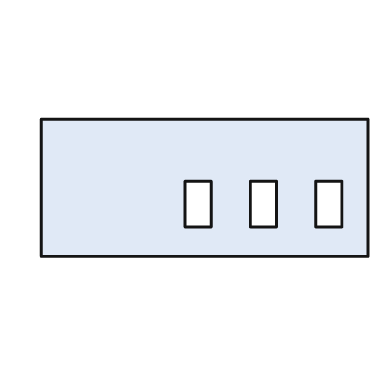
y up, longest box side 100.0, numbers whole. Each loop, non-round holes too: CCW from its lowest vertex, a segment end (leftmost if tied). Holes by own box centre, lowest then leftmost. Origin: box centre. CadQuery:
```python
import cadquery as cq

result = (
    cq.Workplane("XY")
    .moveTo(-50.0, -21.0)
    .lineTo(50.0, -21.0)
    .lineTo(50.0, 21.0)
    .lineTo(-50.0, 21.0)
    .close()
    .moveTo(-6.0, -12.0)
    .lineTo(2.0, -12.0)
    .lineTo(2.0, 2.0)
    .lineTo(-6.0, 2.0)
    .close()
    .moveTo(14.0, -12.0)
    .lineTo(22.0, -12.0)
    .lineTo(22.0, 2.0)
    .lineTo(14.0, 2.0)
    .close()
    .moveTo(34.0, -12.0)
    .lineTo(42.0, -12.0)
    .lineTo(42.0, 2.0)
    .lineTo(34.0, 2.0)
    .close()
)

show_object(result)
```